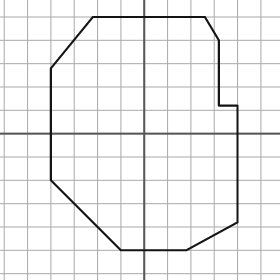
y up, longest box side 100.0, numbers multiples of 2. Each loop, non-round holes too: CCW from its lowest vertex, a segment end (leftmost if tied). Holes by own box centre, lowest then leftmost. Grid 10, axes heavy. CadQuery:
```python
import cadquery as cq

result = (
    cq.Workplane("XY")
    .moveTo(-10.0, -50.0)
    .lineTo(18.0, -50.0)
    .lineTo(40.0, -38.0)
    .lineTo(40.0, 12.0)
    .lineTo(32.0, 12.0)
    .lineTo(32.0, 40.0)
    .lineTo(26.0, 50.0)
    .lineTo(-22.0, 50.0)
    .lineTo(-40.0, 28.0)
    .lineTo(-40.0, -20.0)
    .close()
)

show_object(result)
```